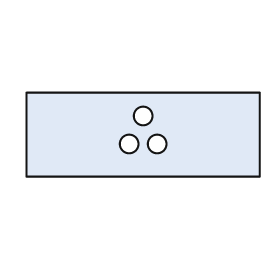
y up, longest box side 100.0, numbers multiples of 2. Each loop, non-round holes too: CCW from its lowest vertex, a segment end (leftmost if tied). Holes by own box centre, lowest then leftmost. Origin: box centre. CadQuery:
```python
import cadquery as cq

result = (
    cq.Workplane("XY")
    .moveTo(-50.0, -18.0)
    .lineTo(50.0, -18.0)
    .lineTo(50.0, 18.0)
    .lineTo(-50.0, 18.0)
    .close()
    .moveTo(-6.0, -4.0)
    .circle(4.0)
    .moveTo(6.0, -4.0)
    .circle(4.0)
    .moveTo(0.0, 8.0)
    .circle(4.0)
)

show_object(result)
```